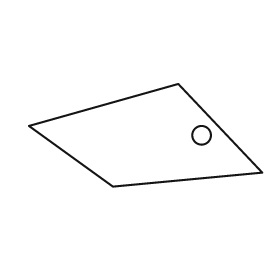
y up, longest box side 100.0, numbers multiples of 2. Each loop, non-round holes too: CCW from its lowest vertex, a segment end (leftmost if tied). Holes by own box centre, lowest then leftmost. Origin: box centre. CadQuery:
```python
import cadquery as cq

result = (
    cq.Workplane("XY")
    .moveTo(-14.0, -22.0)
    .lineTo(50.0, -16.0)
    .lineTo(14.0, 22.0)
    .lineTo(-50.0, 4.0)
    .close()
    .moveTo(24.0, 0.0)
    .circle(4.0)
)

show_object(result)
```